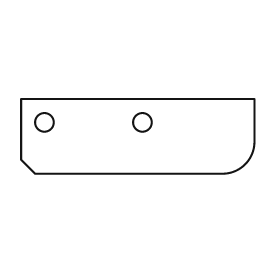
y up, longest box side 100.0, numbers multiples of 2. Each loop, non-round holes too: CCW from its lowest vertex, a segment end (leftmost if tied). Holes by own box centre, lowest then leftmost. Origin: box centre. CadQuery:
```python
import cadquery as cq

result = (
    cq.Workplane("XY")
    .moveTo(-44.0, -16.0)
    .lineTo(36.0, -16.0)
    .threePointArc((46.0, -12.0), (50.0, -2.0))
    .lineTo(50.0, 16.0)
    .lineTo(-50.0, 16.0)
    .lineTo(-50.0, -10.0)
    .close()
    .moveTo(-40.0, 6.0)
    .circle(4.0)
    .moveTo(2.0, 6.0)
    .circle(4.0)
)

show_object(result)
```